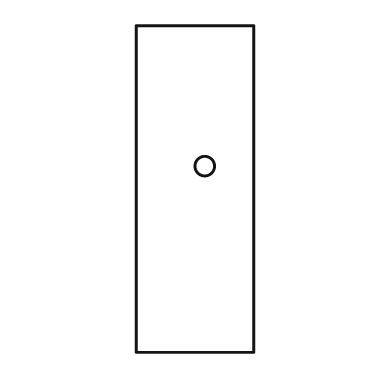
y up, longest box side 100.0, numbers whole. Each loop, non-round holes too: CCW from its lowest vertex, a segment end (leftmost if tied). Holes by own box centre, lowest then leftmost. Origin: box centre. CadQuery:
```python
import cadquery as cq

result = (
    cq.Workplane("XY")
    .moveTo(-18.0, -50.0)
    .lineTo(18.0, -50.0)
    .lineTo(18.0, 50.0)
    .lineTo(-18.0, 50.0)
    .close()
    .moveTo(3.0, 7.0)
    .circle(3.0)
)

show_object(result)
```